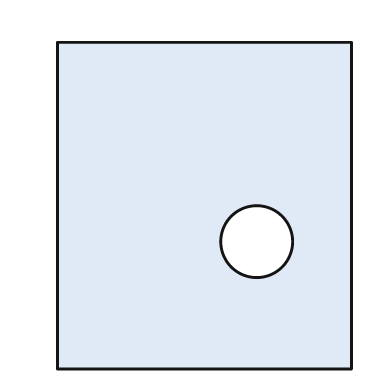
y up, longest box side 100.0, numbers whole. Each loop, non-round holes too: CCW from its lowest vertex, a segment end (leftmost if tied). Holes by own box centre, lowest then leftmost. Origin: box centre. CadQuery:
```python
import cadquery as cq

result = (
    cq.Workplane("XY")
    .moveTo(-45.0, -50.0)
    .lineTo(45.0, -50.0)
    .lineTo(45.0, 50.0)
    .lineTo(-45.0, 50.0)
    .close()
    .moveTo(16.0, -11.0)
    .circle(11.0)
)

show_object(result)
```